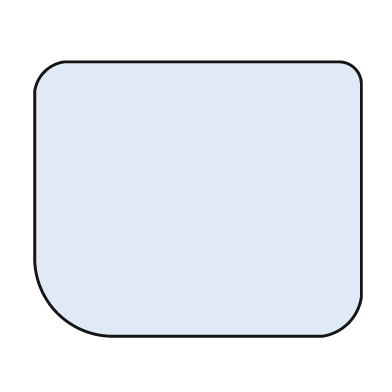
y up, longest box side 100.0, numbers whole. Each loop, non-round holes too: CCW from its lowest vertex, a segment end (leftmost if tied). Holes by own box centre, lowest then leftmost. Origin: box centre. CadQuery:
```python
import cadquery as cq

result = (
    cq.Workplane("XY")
    .moveTo(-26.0, -42.0)
    .lineTo(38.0, -42.0)
    .threePointArc((46.0, -38.0), (50.0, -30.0))
    .lineTo(50.0, 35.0)
    .threePointArc((48.0, 40.0), (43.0, 42.0))
    .lineTo(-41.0, 42.0)
    .threePointArc((-47.0, 39.0), (-50.0, 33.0))
    .lineTo(-50.0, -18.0)
    .threePointArc((-43.0, -35.0), (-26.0, -42.0))
    .close()
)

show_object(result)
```